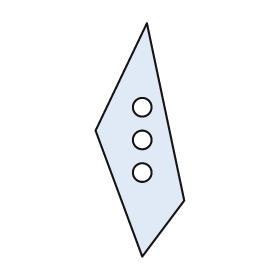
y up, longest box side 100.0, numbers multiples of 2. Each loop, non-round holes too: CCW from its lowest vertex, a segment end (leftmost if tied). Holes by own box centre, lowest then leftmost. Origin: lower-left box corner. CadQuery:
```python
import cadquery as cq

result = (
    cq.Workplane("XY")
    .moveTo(20.0, 0.0)
    .lineTo(38.0, 24.0)
    .lineTo(22.0, 100.0)
    .lineTo(0.0, 54.0)
    .close()
    .moveTo(20.0, 36.0)
    .circle(4.0)
    .moveTo(20.0, 50.0)
    .circle(4.0)
    .moveTo(20.0, 64.0)
    .circle(4.0)
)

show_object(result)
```